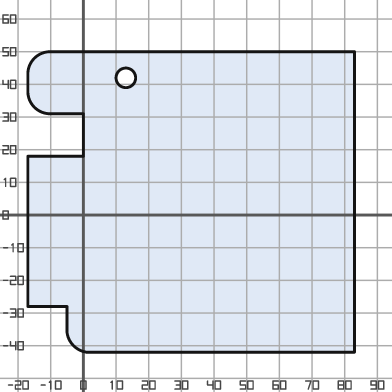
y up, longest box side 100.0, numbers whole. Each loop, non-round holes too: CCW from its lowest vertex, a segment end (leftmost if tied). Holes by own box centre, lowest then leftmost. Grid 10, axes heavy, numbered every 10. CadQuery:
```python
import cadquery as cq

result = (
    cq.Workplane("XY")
    .moveTo(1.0, -42.0)
    .lineTo(83.0, -42.0)
    .lineTo(83.0, 50.0)
    .lineTo(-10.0, 50.0)
    .threePointArc((-15.0, 48.0), (-17.0, 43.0))
    .lineTo(-17.0, 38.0)
    .threePointArc((-15.0, 33.0), (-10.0, 31.0))
    .lineTo(0.0, 31.0)
    .lineTo(0.0, 18.0)
    .lineTo(-17.0, 18.0)
    .lineTo(-17.0, -28.0)
    .lineTo(-5.0, -28.0)
    .lineTo(-5.0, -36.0)
    .threePointArc((-3.0, -40.0), (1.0, -42.0))
    .close()
    .moveTo(13.0, 42.0)
    .circle(3.0)
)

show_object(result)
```